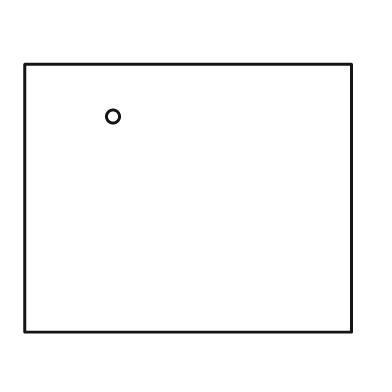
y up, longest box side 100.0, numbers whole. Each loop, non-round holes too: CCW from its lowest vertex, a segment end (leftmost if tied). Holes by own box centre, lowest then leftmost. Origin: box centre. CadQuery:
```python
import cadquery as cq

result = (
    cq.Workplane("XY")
    .moveTo(-50.0, -41.0)
    .lineTo(50.0, -41.0)
    .lineTo(50.0, 41.0)
    .lineTo(-50.0, 41.0)
    .close()
    .moveTo(-23.0, 25.0)
    .circle(2.0)
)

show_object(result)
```